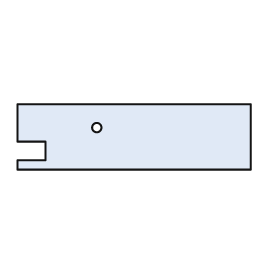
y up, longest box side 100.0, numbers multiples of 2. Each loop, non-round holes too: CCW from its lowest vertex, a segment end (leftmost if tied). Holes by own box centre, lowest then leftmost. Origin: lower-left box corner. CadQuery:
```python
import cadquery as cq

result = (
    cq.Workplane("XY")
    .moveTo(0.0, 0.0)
    .lineTo(100.0, 0.0)
    .lineTo(100.0, 28.0)
    .lineTo(0.0, 28.0)
    .lineTo(0.0, 12.0)
    .lineTo(12.0, 12.0)
    .lineTo(12.0, 4.0)
    .lineTo(0.0, 4.0)
    .close()
    .moveTo(34.0, 18.0)
    .circle(2.0)
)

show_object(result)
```